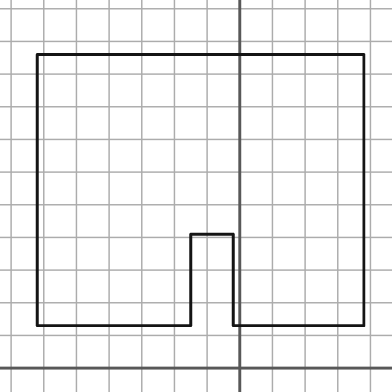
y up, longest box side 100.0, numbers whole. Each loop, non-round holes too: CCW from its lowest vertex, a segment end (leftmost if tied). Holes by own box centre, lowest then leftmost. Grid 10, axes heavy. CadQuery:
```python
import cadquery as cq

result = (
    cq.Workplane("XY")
    .moveTo(-62.0, 13.0)
    .lineTo(-15.0, 13.0)
    .lineTo(-15.0, 41.0)
    .lineTo(-2.0, 41.0)
    .lineTo(-2.0, 13.0)
    .lineTo(38.0, 13.0)
    .lineTo(38.0, 96.0)
    .lineTo(-62.0, 96.0)
    .close()
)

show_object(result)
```